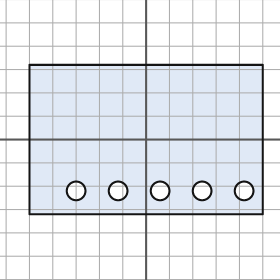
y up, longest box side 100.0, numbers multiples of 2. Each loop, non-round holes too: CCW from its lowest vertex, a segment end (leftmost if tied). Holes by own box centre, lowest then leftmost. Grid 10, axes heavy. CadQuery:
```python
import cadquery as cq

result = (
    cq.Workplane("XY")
    .moveTo(-50.0, -32.0)
    .lineTo(50.0, -32.0)
    .lineTo(50.0, 32.0)
    .lineTo(-50.0, 32.0)
    .close()
    .moveTo(-30.0, -22.0)
    .circle(4.0)
    .moveTo(-12.0, -22.0)
    .circle(4.0)
    .moveTo(6.0, -22.0)
    .circle(4.0)
    .moveTo(24.0, -22.0)
    .circle(4.0)
    .moveTo(42.0, -22.0)
    .circle(4.0)
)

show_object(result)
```